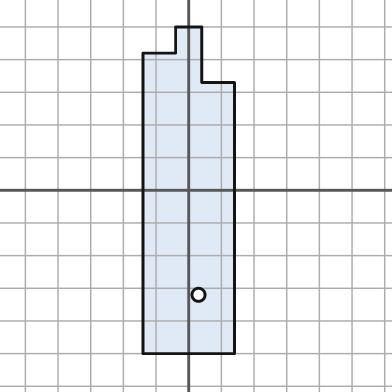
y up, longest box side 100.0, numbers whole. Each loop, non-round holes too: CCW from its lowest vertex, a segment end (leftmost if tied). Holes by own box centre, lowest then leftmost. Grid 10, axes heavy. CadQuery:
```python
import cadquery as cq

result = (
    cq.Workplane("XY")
    .moveTo(-14.0, -50.0)
    .lineTo(14.0, -50.0)
    .lineTo(14.0, 33.0)
    .lineTo(4.0, 33.0)
    .lineTo(4.0, 50.0)
    .lineTo(-4.0, 50.0)
    .lineTo(-4.0, 42.0)
    .lineTo(-14.0, 42.0)
    .close()
    .moveTo(3.0, -32.0)
    .circle(2.0)
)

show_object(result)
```